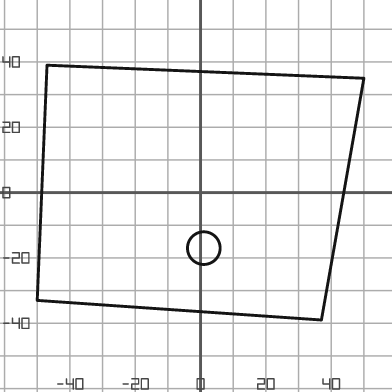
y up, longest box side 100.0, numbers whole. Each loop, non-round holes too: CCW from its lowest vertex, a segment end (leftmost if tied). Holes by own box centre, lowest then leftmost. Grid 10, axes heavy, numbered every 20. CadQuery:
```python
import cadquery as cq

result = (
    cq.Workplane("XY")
    .moveTo(37.0, -39.0)
    .lineTo(50.0, 35.0)
    .lineTo(-47.0, 39.0)
    .lineTo(-50.0, -33.0)
    .close()
    .moveTo(1.0, -17.0)
    .circle(5.0)
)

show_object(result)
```